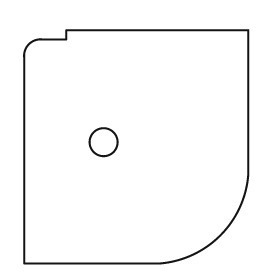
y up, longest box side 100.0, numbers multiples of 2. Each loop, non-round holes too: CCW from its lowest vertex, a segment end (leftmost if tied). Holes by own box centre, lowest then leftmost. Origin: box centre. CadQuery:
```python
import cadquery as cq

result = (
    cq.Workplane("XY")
    .moveTo(-48.0, -50.0)
    .lineTo(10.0, -50.0)
    .threePointArc((36.0, -38.0), (48.0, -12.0))
    .lineTo(48.0, 50.0)
    .lineTo(-30.0, 50.0)
    .lineTo(-30.0, 46.0)
    .lineTo(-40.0, 46.0)
    .threePointArc((-46.0, 44.0), (-48.0, 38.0))
    .close()
    .moveTo(-14.0, 2.0)
    .circle(6.0)
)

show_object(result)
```